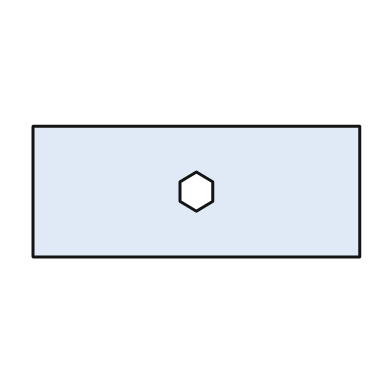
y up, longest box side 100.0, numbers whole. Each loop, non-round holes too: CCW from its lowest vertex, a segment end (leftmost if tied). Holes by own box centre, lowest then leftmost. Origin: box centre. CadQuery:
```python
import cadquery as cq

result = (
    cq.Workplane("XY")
    .moveTo(-50.0, -20.0)
    .lineTo(50.0, -20.0)
    .lineTo(50.0, 20.0)
    .lineTo(-50.0, 20.0)
    .close()
    .moveTo(0.0, -6.0)
    .lineTo(5.0, -3.0)
    .lineTo(5.0, 3.0)
    .lineTo(0.0, 6.0)
    .lineTo(-5.0, 3.0)
    .lineTo(-5.0, -3.0)
    .close()
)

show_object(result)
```